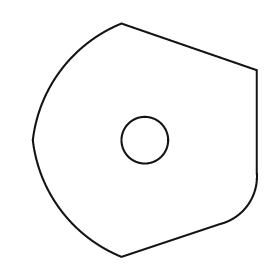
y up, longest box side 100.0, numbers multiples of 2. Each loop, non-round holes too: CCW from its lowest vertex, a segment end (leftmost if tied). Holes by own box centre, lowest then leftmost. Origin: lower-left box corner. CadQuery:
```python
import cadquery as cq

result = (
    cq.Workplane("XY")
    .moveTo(38.0, 0.0)
    .lineTo(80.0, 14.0)
    .threePointArc((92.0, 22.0), (96.0, 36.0))
    .lineTo(96.0, 80.0)
    .lineTo(38.0, 100.0)
    .threePointArc((12.0, 80.0), (0.0, 50.0))
    .threePointArc((12.0, 20.0), (38.0, 0.0))
    .close()
    .moveTo(48.0, 50.0)
    .circle(10.0)
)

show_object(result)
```